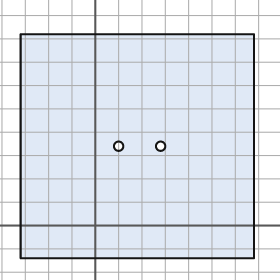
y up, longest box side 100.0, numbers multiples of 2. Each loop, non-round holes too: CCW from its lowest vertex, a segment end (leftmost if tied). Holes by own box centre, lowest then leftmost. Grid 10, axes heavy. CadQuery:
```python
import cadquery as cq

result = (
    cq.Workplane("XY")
    .moveTo(-32.0, -14.0)
    .lineTo(68.0, -14.0)
    .lineTo(68.0, 82.0)
    .lineTo(-32.0, 82.0)
    .close()
    .moveTo(10.0, 34.0)
    .circle(2.0)
    .moveTo(28.0, 34.0)
    .circle(2.0)
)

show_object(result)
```